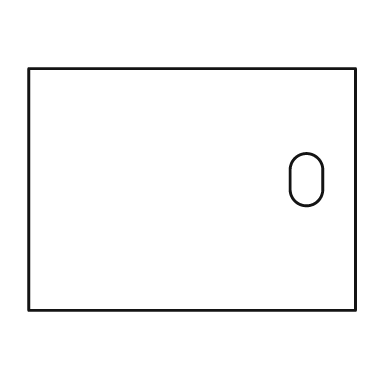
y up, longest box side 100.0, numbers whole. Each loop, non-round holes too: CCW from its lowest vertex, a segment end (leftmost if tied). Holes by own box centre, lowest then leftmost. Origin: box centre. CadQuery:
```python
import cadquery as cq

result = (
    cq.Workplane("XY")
    .moveTo(-50.0, -37.0)
    .lineTo(50.0, -37.0)
    .lineTo(50.0, 37.0)
    .lineTo(-50.0, 37.0)
    .close()
    .moveTo(30.0, 0.0)
    .threePointArc((35.0, -5.0), (40.0, 0.0))
    .lineTo(40.0, 6.0)
    .threePointArc((35.0, 11.0), (30.0, 6.0))
    .close()
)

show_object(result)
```